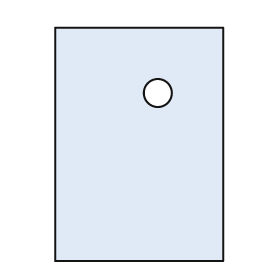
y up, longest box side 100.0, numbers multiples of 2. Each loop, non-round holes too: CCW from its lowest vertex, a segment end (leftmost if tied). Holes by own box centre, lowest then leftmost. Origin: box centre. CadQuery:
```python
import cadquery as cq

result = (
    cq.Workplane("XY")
    .moveTo(-36.0, -50.0)
    .lineTo(36.0, -50.0)
    .lineTo(36.0, 50.0)
    .lineTo(-36.0, 50.0)
    .close()
    .moveTo(8.0, 22.0)
    .circle(6.0)
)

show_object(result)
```